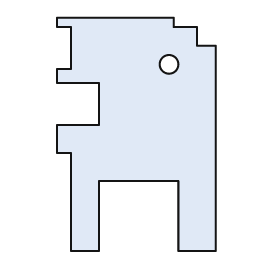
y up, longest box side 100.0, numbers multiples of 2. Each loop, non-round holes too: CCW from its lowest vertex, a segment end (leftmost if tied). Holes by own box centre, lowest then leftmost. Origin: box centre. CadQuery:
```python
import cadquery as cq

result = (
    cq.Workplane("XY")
    .moveTo(-28.0, -50.0)
    .lineTo(-16.0, -50.0)
    .lineTo(-16.0, -20.0)
    .lineTo(18.0, -20.0)
    .lineTo(18.0, -50.0)
    .lineTo(34.0, -50.0)
    .lineTo(34.0, 38.0)
    .lineTo(26.0, 38.0)
    .lineTo(26.0, 46.0)
    .lineTo(16.0, 46.0)
    .lineTo(16.0, 50.0)
    .lineTo(-34.0, 50.0)
    .lineTo(-34.0, 46.0)
    .lineTo(-28.0, 46.0)
    .lineTo(-28.0, 28.0)
    .lineTo(-34.0, 28.0)
    .lineTo(-34.0, 22.0)
    .lineTo(-16.0, 22.0)
    .lineTo(-16.0, 4.0)
    .lineTo(-34.0, 4.0)
    .lineTo(-34.0, -8.0)
    .lineTo(-28.0, -8.0)
    .close()
    .moveTo(14.0, 30.0)
    .circle(4.0)
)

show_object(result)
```